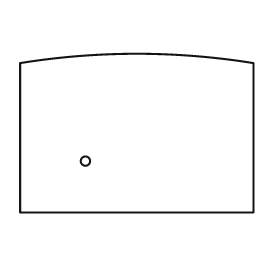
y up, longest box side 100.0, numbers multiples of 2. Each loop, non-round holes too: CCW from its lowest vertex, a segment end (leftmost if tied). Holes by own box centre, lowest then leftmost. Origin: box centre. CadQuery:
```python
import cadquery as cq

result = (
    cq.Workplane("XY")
    .moveTo(-50.0, -34.0)
    .lineTo(50.0, -34.0)
    .lineTo(50.0, 30.0)
    .threePointArc((0.0, 34.0), (-50.0, 30.0))
    .close()
    .moveTo(-22.0, -12.0)
    .circle(2.0)
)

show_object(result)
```